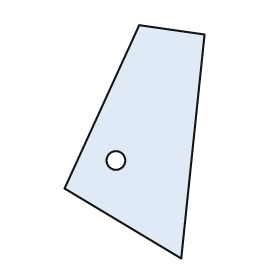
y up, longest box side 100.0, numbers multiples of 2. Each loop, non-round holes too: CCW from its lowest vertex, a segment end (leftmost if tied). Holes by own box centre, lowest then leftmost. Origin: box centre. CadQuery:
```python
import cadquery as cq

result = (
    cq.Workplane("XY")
    .moveTo(20.0, -50.0)
    .lineTo(30.0, 46.0)
    .lineTo(2.0, 50.0)
    .lineTo(-30.0, -20.0)
    .close()
    .moveTo(-8.0, -8.0)
    .circle(4.0)
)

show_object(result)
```